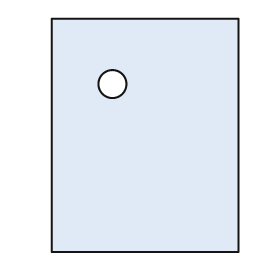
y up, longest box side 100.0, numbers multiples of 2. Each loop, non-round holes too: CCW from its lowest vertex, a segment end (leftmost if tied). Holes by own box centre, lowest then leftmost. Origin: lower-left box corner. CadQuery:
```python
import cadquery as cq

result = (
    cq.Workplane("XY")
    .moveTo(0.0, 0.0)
    .lineTo(80.0, 0.0)
    .lineTo(80.0, 100.0)
    .lineTo(0.0, 100.0)
    .close()
    .moveTo(26.0, 72.0)
    .circle(6.0)
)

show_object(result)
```